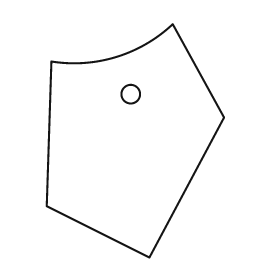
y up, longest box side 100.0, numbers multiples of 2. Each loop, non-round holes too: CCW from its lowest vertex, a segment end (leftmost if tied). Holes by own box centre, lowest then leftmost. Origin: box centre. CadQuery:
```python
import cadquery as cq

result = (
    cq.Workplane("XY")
    .moveTo(6.0, -50.0)
    .lineTo(38.0, 10.0)
    .lineTo(16.0, 50.0)
    .threePointArc((-8.0, 36.0), (-36.0, 34.0))
    .lineTo(-38.0, -28.0)
    .close()
    .moveTo(-2.0, 20.0)
    .circle(4.0)
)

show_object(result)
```